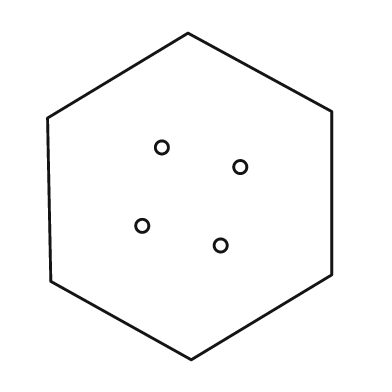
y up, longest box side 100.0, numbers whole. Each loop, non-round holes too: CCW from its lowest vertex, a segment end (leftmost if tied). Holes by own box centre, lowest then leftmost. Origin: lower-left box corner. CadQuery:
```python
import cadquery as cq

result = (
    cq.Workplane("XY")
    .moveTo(44.0, 0.0)
    .lineTo(87.0, 26.0)
    .lineTo(87.0, 76.0)
    .lineTo(43.0, 100.0)
    .lineTo(0.0, 74.0)
    .lineTo(1.0, 24.0)
    .close()
    .moveTo(53.0, 35.0)
    .circle(2.0)
    .moveTo(29.0, 41.0)
    .circle(2.0)
    .moveTo(59.0, 59.0)
    .circle(2.0)
    .moveTo(35.0, 65.0)
    .circle(2.0)
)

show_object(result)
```